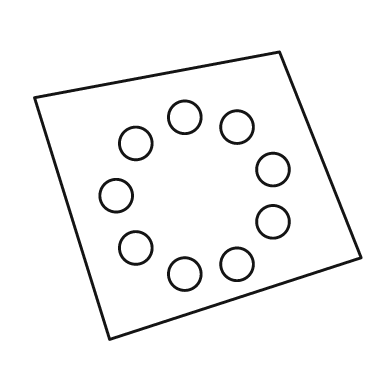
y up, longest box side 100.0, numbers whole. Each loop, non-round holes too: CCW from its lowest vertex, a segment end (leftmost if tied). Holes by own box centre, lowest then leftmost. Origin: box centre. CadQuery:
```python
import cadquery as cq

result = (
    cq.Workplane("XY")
    .moveTo(-27.0, -44.0)
    .lineTo(50.0, -19.0)
    .lineTo(25.0, 44.0)
    .lineTo(-50.0, 30.0)
    .close()
    .moveTo(-4.0, -24.0)
    .circle(5.0)
    .moveTo(12.0, -21.0)
    .circle(5.0)
    .moveTo(-19.0, -16.0)
    .circle(5.0)
    .moveTo(23.0, -8.0)
    .circle(5.0)
    .moveTo(-25.0, 0.0)
    .circle(5.0)
    .moveTo(23.0, 8.0)
    .circle(5.0)
    .moveTo(-19.0, 16.0)
    .circle(5.0)
    .moveTo(12.0, 21.0)
    .circle(5.0)
    .moveTo(-4.0, 24.0)
    .circle(5.0)
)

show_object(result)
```